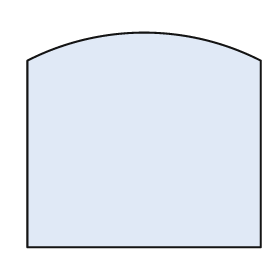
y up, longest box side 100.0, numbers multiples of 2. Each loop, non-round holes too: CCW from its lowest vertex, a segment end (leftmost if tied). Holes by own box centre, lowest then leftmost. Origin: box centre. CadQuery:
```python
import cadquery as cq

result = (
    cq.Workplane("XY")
    .moveTo(-50.0, -46.0)
    .lineTo(50.0, -46.0)
    .lineTo(50.0, 34.0)
    .threePointArc((0.0, 46.0), (-50.0, 34.0))
    .close()
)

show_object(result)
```